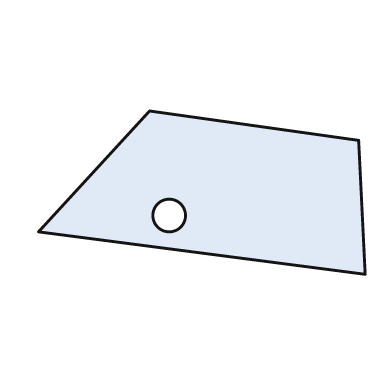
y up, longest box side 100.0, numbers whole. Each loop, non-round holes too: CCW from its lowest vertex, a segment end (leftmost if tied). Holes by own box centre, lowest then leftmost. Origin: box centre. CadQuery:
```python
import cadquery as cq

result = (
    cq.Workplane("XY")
    .moveTo(50.0, -25.0)
    .lineTo(48.0, 16.0)
    .lineTo(-16.0, 25.0)
    .lineTo(-50.0, -12.0)
    .close()
    .moveTo(-10.0, -7.0)
    .circle(5.0)
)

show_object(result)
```